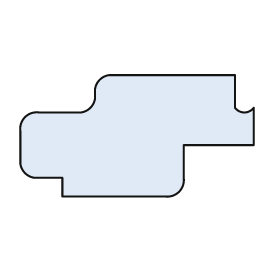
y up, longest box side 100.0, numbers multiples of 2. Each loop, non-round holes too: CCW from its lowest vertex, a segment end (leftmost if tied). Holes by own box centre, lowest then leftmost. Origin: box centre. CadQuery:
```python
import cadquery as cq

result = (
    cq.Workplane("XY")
    .moveTo(-32.0, -26.0)
    .lineTo(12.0, -26.0)
    .threePointArc((18.0, -24.0), (20.0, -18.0))
    .lineTo(20.0, -4.0)
    .lineTo(50.0, -4.0)
    .lineTo(50.0, 12.0)
    .threePointArc((46.0, 10.0), (42.0, 12.0))
    .lineTo(42.0, 26.0)
    .lineTo(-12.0, 26.0)
    .threePointArc((-16.0, 24.0), (-18.0, 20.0))
    .lineTo(-18.0, 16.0)
    .threePointArc((-20.0, 12.0), (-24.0, 10.0))
    .lineTo(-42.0, 10.0)
    .threePointArc((-48.0, 8.0), (-50.0, 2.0))
    .lineTo(-50.0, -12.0)
    .threePointArc((-48.0, -16.0), (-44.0, -18.0))
    .lineTo(-32.0, -18.0)
    .close()
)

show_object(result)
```